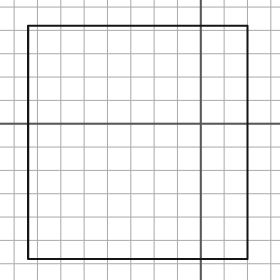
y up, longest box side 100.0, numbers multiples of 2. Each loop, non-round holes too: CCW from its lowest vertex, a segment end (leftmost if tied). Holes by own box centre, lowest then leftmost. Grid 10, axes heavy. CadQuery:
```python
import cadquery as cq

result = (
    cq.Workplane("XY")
    .moveTo(-74.0, -58.0)
    .lineTo(20.0, -58.0)
    .lineTo(20.0, 42.0)
    .lineTo(-74.0, 42.0)
    .close()
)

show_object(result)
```